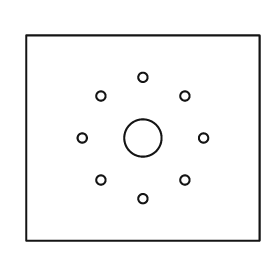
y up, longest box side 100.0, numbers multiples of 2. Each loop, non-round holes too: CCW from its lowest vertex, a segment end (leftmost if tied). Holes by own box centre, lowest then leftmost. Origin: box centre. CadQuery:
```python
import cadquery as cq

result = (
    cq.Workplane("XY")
    .moveTo(-50.0, -44.0)
    .lineTo(50.0, -44.0)
    .lineTo(50.0, 44.0)
    .lineTo(-50.0, 44.0)
    .close()
    .moveTo(0.0, -26.0)
    .circle(2.0)
    .moveTo(-18.0, -18.0)
    .circle(2.0)
    .moveTo(18.0, -18.0)
    .circle(2.0)
    .moveTo(-26.0, 0.0)
    .circle(2.0)
    .moveTo(0.0, 0.0)
    .circle(8.0)
    .moveTo(26.0, 0.0)
    .circle(2.0)
    .moveTo(-18.0, 18.0)
    .circle(2.0)
    .moveTo(18.0, 18.0)
    .circle(2.0)
    .moveTo(0.0, 26.0)
    .circle(2.0)
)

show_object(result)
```